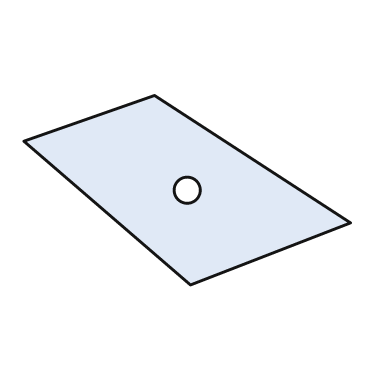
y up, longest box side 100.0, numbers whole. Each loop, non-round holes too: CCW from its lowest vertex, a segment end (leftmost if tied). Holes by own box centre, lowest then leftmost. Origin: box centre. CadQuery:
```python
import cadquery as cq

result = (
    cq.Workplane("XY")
    .moveTo(1.0, -29.0)
    .lineTo(50.0, -10.0)
    .lineTo(-10.0, 29.0)
    .lineTo(-50.0, 15.0)
    .close()
    .moveTo(0.0, 0.0)
    .circle(4.0)
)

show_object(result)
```